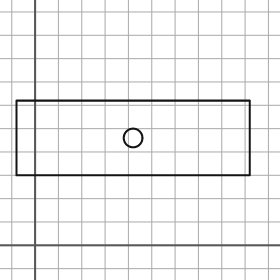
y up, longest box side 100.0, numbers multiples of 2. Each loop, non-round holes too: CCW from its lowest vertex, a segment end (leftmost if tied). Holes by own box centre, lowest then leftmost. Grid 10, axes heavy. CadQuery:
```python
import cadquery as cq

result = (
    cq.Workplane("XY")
    .moveTo(-8.0, 30.0)
    .lineTo(92.0, 30.0)
    .lineTo(92.0, 62.0)
    .lineTo(-8.0, 62.0)
    .close()
    .moveTo(42.0, 46.0)
    .circle(4.0)
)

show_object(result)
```